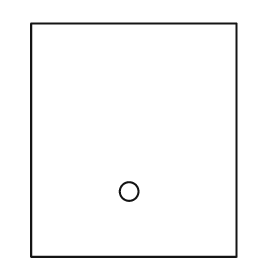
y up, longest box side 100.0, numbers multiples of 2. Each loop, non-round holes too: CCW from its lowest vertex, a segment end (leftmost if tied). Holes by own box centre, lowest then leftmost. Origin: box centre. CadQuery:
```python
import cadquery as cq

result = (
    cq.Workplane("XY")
    .moveTo(-44.0, -50.0)
    .lineTo(44.0, -50.0)
    .lineTo(44.0, 50.0)
    .lineTo(-44.0, 50.0)
    .close()
    .moveTo(-2.0, -22.0)
    .circle(4.0)
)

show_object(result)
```